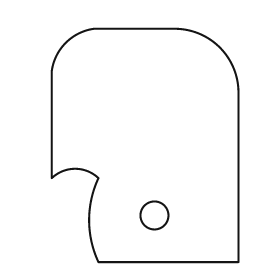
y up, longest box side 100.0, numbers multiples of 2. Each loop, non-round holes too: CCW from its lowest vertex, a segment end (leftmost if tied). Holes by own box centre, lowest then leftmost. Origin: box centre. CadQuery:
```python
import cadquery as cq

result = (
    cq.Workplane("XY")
    .moveTo(-20.0, -50.0)
    .lineTo(40.0, -50.0)
    .lineTo(40.0, 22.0)
    .threePointArc((32.0, 42.0), (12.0, 50.0))
    .lineTo(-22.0, 50.0)
    .threePointArc((-34.0, 44.0), (-40.0, 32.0))
    .lineTo(-40.0, -14.0)
    .threePointArc((-30.0, -10.0), (-20.0, -14.0))
    .threePointArc((-24.0, -32.0), (-20.0, -50.0))
    .close()
    .moveTo(4.0, -30.0)
    .circle(6.0)
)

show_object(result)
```